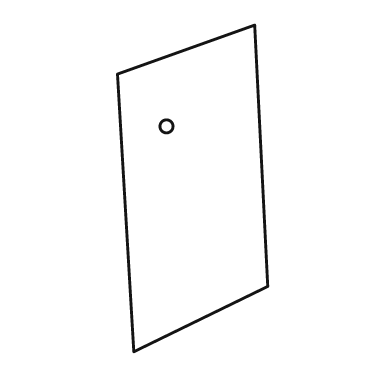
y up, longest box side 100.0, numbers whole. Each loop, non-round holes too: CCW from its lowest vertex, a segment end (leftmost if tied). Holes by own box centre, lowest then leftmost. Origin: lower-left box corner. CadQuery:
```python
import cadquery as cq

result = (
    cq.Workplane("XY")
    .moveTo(5.0, 0.0)
    .lineTo(46.0, 20.0)
    .lineTo(42.0, 100.0)
    .lineTo(0.0, 85.0)
    .close()
    .moveTo(15.0, 69.0)
    .circle(2.0)
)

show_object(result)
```